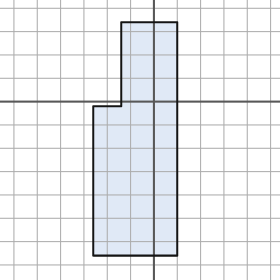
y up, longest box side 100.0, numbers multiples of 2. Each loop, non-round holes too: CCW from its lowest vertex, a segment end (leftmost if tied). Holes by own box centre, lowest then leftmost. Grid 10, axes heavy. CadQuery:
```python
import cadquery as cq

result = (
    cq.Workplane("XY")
    .moveTo(-26.0, -66.0)
    .lineTo(10.0, -66.0)
    .lineTo(10.0, 34.0)
    .lineTo(-14.0, 34.0)
    .lineTo(-14.0, -2.0)
    .lineTo(-26.0, -2.0)
    .close()
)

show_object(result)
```